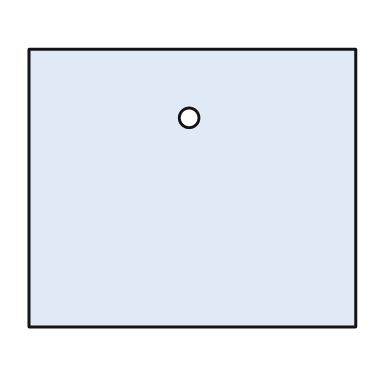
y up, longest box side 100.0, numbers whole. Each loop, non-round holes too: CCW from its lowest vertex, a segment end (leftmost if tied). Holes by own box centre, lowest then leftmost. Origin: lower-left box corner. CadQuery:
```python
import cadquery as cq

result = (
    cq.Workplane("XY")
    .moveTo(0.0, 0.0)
    .lineTo(100.0, 0.0)
    .lineTo(100.0, 85.0)
    .lineTo(0.0, 85.0)
    .close()
    .moveTo(49.0, 64.0)
    .circle(3.0)
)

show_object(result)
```